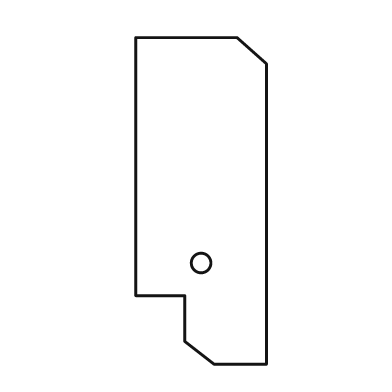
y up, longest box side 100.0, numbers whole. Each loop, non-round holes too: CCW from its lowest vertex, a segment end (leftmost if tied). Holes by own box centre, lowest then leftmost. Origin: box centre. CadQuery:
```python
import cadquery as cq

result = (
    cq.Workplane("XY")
    .moveTo(4.0, -50.0)
    .lineTo(20.0, -50.0)
    .lineTo(20.0, 42.0)
    .lineTo(11.0, 50.0)
    .lineTo(-20.0, 50.0)
    .lineTo(-20.0, -29.0)
    .lineTo(-5.0, -29.0)
    .lineTo(-5.0, -43.0)
    .close()
    .moveTo(0.0, -19.0)
    .circle(3.0)
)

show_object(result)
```